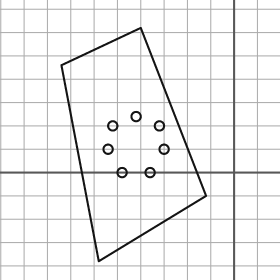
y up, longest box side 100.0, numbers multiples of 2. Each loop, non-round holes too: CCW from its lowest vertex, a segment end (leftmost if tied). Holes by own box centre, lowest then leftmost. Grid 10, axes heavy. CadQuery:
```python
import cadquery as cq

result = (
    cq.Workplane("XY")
    .moveTo(-58.0, -38.0)
    .lineTo(-12.0, -10.0)
    .lineTo(-40.0, 62.0)
    .lineTo(-74.0, 46.0)
    .close()
    .moveTo(-48.0, 0.0)
    .circle(2.0)
    .moveTo(-36.0, 0.0)
    .circle(2.0)
    .moveTo(-54.0, 10.0)
    .circle(2.0)
    .moveTo(-30.0, 10.0)
    .circle(2.0)
    .moveTo(-52.0, 20.0)
    .circle(2.0)
    .moveTo(-32.0, 20.0)
    .circle(2.0)
    .moveTo(-42.0, 24.0)
    .circle(2.0)
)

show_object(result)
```